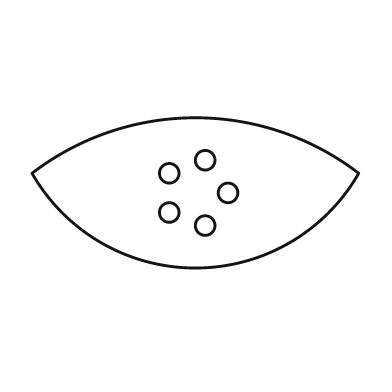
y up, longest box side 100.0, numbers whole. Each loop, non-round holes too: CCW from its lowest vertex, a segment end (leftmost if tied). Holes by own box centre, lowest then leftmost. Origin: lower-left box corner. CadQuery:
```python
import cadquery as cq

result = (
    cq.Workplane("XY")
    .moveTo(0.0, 29.0)
    .threePointArc((50.0, 0.0), (100.0, 29.0))
    .threePointArc((50.0, 46.0), (0.0, 29.0))
    .close()
    .moveTo(53.0, 13.0)
    .circle(3.0)
    .moveTo(42.0, 17.0)
    .circle(3.0)
    .moveTo(60.0, 23.0)
    .circle(3.0)
    .moveTo(42.0, 29.0)
    .circle(3.0)
    .moveTo(53.0, 33.0)
    .circle(3.0)
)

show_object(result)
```